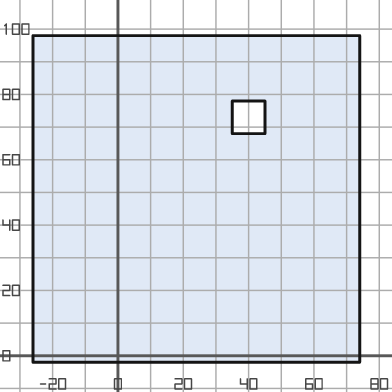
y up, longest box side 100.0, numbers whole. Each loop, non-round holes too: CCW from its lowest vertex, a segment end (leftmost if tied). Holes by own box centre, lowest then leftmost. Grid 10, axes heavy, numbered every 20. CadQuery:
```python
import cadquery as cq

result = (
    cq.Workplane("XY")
    .moveTo(-26.0, -2.0)
    .lineTo(74.0, -2.0)
    .lineTo(74.0, 98.0)
    .lineTo(-26.0, 98.0)
    .close()
    .moveTo(35.0, 68.0)
    .lineTo(45.0, 68.0)
    .lineTo(45.0, 78.0)
    .lineTo(35.0, 78.0)
    .close()
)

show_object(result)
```